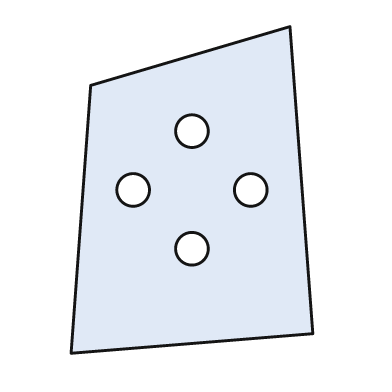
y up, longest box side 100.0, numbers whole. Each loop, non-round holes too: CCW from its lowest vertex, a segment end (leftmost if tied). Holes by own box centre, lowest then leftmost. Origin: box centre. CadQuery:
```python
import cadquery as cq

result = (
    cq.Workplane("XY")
    .moveTo(-37.0, -50.0)
    .lineTo(37.0, -44.0)
    .lineTo(30.0, 50.0)
    .lineTo(-31.0, 32.0)
    .close()
    .moveTo(0.0, -18.0)
    .circle(5.0)
    .moveTo(-18.0, 0.0)
    .circle(5.0)
    .moveTo(18.0, 0.0)
    .circle(5.0)
    .moveTo(0.0, 18.0)
    .circle(5.0)
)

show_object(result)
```